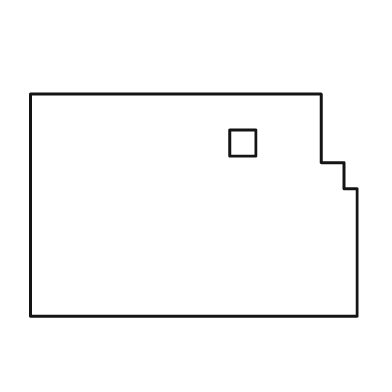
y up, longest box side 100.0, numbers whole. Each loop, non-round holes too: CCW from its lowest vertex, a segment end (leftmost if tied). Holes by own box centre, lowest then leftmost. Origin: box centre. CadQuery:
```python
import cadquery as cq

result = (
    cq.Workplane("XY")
    .moveTo(-50.0, -34.0)
    .lineTo(50.0, -34.0)
    .lineTo(50.0, 5.0)
    .lineTo(46.0, 5.0)
    .lineTo(46.0, 13.0)
    .lineTo(39.0, 13.0)
    .lineTo(39.0, 34.0)
    .lineTo(-50.0, 34.0)
    .close()
    .moveTo(11.0, 15.0)
    .lineTo(19.0, 15.0)
    .lineTo(19.0, 23.0)
    .lineTo(11.0, 23.0)
    .close()
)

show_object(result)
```